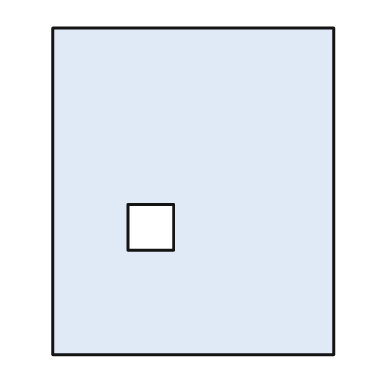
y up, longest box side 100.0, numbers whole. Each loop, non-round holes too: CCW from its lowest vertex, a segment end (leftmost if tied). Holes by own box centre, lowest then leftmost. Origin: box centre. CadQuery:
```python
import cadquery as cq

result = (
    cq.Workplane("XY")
    .moveTo(-43.0, -50.0)
    .lineTo(43.0, -50.0)
    .lineTo(43.0, 50.0)
    .lineTo(-43.0, 50.0)
    .close()
    .moveTo(-20.0, -18.0)
    .lineTo(-6.0, -18.0)
    .lineTo(-6.0, -4.0)
    .lineTo(-20.0, -4.0)
    .close()
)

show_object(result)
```